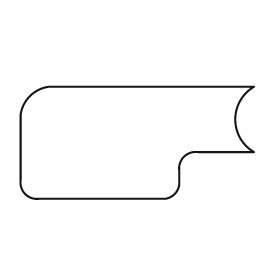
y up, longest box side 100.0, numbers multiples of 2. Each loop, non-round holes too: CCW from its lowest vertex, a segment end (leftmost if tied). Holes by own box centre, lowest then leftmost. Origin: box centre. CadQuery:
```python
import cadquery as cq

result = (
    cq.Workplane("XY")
    .moveTo(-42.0, -24.0)
    .lineTo(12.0, -24.0)
    .threePointArc((16.0, -22.0), (18.0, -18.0))
    .lineTo(18.0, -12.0)
    .threePointArc((20.0, -6.0), (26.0, -4.0))
    .lineTo(50.0, -4.0)
    .threePointArc((42.0, 10.0), (50.0, 24.0))
    .lineTo(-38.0, 24.0)
    .threePointArc((-46.0, 20.0), (-50.0, 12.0))
    .lineTo(-50.0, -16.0)
    .threePointArc((-48.0, -22.0), (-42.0, -24.0))
    .close()
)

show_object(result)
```